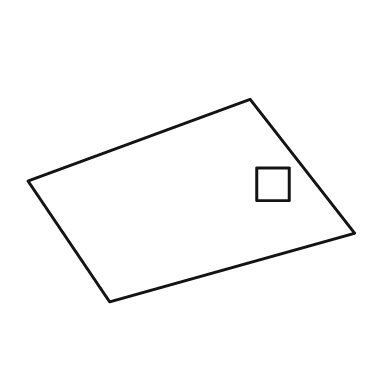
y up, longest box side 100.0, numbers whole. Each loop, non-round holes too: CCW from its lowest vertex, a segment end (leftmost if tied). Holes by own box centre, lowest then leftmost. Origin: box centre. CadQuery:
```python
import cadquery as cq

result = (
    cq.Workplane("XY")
    .moveTo(-25.0, -31.0)
    .lineTo(50.0, -10.0)
    .lineTo(18.0, 31.0)
    .lineTo(-50.0, 6.0)
    .close()
    .moveTo(20.0, 0.0)
    .lineTo(30.0, 0.0)
    .lineTo(30.0, 10.0)
    .lineTo(20.0, 10.0)
    .close()
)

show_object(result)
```